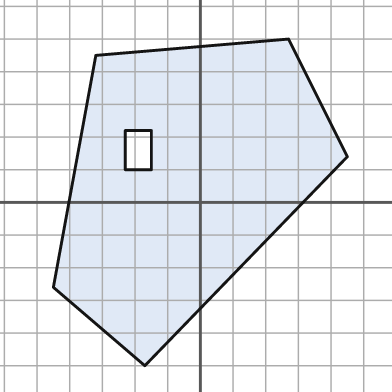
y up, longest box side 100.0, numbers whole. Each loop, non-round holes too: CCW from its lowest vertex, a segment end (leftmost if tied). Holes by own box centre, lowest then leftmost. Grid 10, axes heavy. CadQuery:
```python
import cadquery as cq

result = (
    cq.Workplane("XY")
    .moveTo(-17.0, -50.0)
    .lineTo(45.0, 14.0)
    .lineTo(27.0, 50.0)
    .lineTo(-32.0, 45.0)
    .lineTo(-45.0, -26.0)
    .close()
    .moveTo(-23.0, 10.0)
    .lineTo(-15.0, 10.0)
    .lineTo(-15.0, 22.0)
    .lineTo(-23.0, 22.0)
    .close()
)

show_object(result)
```